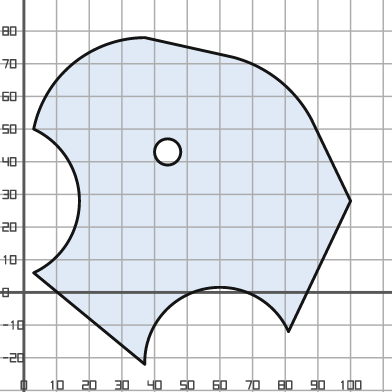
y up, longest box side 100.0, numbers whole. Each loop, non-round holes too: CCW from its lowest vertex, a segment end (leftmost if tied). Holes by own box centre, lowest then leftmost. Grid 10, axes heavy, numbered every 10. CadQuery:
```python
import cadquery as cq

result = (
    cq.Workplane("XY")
    .moveTo(37.0, -22.0)
    .threePointArc((55.0, 1.0), (81.0, -12.0))
    .lineTo(100.0, 28.0)
    .lineTo(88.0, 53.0)
    .threePointArc((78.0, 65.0), (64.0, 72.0))
    .lineTo(37.0, 78.0)
    .threePointArc((15.0, 70.0), (3.0, 50.0))
    .threePointArc((17.0, 28.0), (3.0, 6.0))
    .close()
    .moveTo(44.0, 43.0)
    .circle(4.0)
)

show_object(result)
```